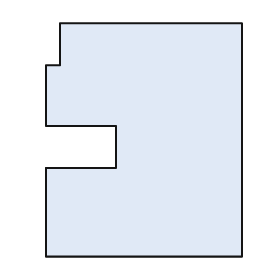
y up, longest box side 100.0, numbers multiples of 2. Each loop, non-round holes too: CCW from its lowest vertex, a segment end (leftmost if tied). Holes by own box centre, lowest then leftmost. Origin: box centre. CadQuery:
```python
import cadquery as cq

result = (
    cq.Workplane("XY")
    .moveTo(-42.0, -50.0)
    .lineTo(42.0, -50.0)
    .lineTo(42.0, 50.0)
    .lineTo(-36.0, 50.0)
    .lineTo(-36.0, 32.0)
    .lineTo(-42.0, 32.0)
    .lineTo(-42.0, 6.0)
    .lineTo(-12.0, 6.0)
    .lineTo(-12.0, -12.0)
    .lineTo(-42.0, -12.0)
    .close()
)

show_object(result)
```